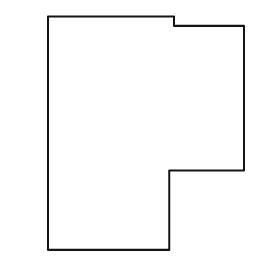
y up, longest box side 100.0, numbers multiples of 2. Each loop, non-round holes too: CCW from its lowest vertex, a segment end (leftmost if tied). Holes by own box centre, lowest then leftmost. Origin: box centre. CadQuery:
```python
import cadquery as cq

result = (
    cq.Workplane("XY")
    .moveTo(-42.0, -50.0)
    .lineTo(10.0, -50.0)
    .lineTo(10.0, -16.0)
    .lineTo(42.0, -16.0)
    .lineTo(42.0, 46.0)
    .lineTo(12.0, 46.0)
    .lineTo(12.0, 50.0)
    .lineTo(-42.0, 50.0)
    .close()
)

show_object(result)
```